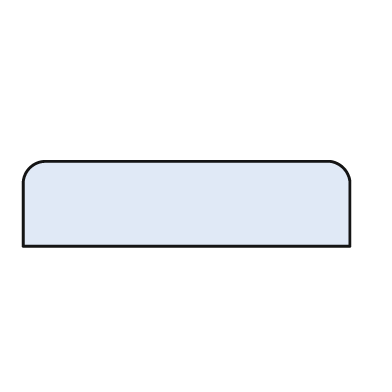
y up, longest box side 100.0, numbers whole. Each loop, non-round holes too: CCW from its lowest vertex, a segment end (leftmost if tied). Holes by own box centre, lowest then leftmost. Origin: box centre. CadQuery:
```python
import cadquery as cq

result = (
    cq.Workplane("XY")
    .moveTo(-50.0, -13.0)
    .lineTo(50.0, -13.0)
    .lineTo(50.0, 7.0)
    .threePointArc((48.0, 11.0), (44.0, 13.0))
    .lineTo(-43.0, 13.0)
    .threePointArc((-48.0, 11.0), (-50.0, 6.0))
    .close()
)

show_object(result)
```